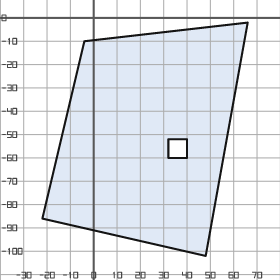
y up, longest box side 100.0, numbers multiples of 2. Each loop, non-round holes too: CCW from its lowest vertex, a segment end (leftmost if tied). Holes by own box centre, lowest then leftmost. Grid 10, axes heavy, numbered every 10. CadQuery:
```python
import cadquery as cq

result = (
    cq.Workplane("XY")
    .moveTo(48.0, -102.0)
    .lineTo(66.0, -2.0)
    .lineTo(-4.0, -10.0)
    .lineTo(-22.0, -86.0)
    .close()
    .moveTo(32.0, -60.0)
    .lineTo(40.0, -60.0)
    .lineTo(40.0, -52.0)
    .lineTo(32.0, -52.0)
    .close()
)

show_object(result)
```